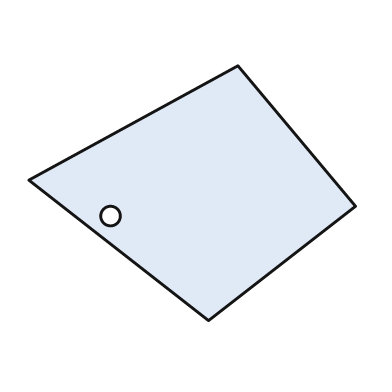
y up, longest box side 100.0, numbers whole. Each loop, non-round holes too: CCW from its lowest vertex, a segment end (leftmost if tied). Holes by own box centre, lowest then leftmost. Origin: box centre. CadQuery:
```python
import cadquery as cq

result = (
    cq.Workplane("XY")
    .moveTo(5.0, -39.0)
    .lineTo(50.0, -4.0)
    .lineTo(14.0, 39.0)
    .lineTo(-50.0, 4.0)
    .close()
    .moveTo(-25.0, -7.0)
    .circle(3.0)
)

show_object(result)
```